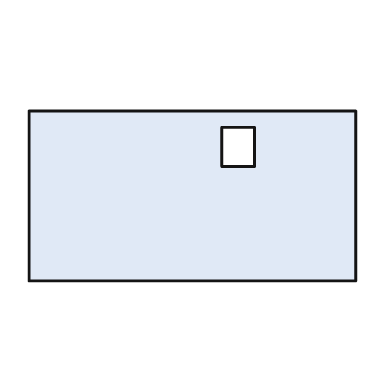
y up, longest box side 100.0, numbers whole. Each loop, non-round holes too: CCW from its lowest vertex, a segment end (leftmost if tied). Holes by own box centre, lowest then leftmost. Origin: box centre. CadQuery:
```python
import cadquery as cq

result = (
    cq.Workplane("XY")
    .moveTo(-50.0, -26.0)
    .lineTo(50.0, -26.0)
    .lineTo(50.0, 26.0)
    .lineTo(-50.0, 26.0)
    .close()
    .moveTo(9.0, 9.0)
    .lineTo(19.0, 9.0)
    .lineTo(19.0, 21.0)
    .lineTo(9.0, 21.0)
    .close()
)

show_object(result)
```